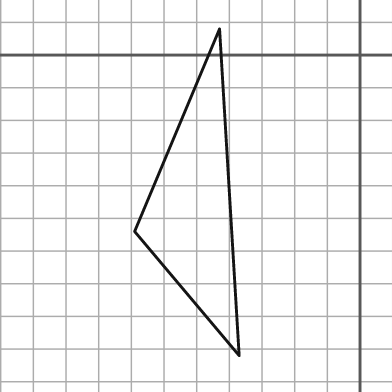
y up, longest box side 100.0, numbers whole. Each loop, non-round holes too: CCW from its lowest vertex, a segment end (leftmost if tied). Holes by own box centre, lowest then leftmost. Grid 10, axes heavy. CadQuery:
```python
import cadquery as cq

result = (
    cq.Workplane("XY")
    .moveTo(-37.0, -92.0)
    .lineTo(-43.0, 8.0)
    .lineTo(-69.0, -54.0)
    .close()
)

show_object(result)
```